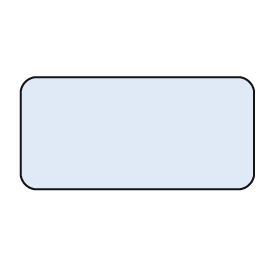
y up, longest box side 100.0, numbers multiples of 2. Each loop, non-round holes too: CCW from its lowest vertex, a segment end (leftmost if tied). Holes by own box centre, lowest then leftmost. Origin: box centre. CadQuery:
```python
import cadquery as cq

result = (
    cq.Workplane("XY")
    .moveTo(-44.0, -24.0)
    .lineTo(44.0, -24.0)
    .threePointArc((48.0, -22.0), (50.0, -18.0))
    .lineTo(50.0, 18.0)
    .threePointArc((48.0, 22.0), (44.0, 24.0))
    .lineTo(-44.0, 24.0)
    .threePointArc((-48.0, 22.0), (-50.0, 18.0))
    .lineTo(-50.0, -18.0)
    .threePointArc((-48.0, -22.0), (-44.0, -24.0))
    .close()
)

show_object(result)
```